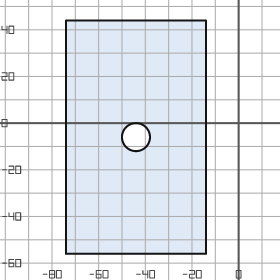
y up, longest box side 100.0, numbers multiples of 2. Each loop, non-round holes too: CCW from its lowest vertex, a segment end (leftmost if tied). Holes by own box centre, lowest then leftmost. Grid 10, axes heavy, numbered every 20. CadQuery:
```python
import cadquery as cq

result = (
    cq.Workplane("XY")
    .moveTo(-74.0, -56.0)
    .lineTo(-14.0, -56.0)
    .lineTo(-14.0, 44.0)
    .lineTo(-74.0, 44.0)
    .close()
    .moveTo(-44.0, -6.0)
    .circle(6.0)
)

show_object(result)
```